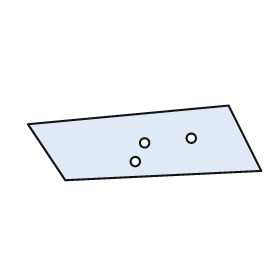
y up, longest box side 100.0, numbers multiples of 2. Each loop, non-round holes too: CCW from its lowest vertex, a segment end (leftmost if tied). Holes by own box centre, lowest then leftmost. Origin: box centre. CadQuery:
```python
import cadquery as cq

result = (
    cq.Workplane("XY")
    .moveTo(-34.0, -16.0)
    .lineTo(50.0, -12.0)
    .lineTo(36.0, 16.0)
    .lineTo(-50.0, 8.0)
    .close()
    .moveTo(-4.0, -8.0)
    .circle(2.0)
    .moveTo(0.0, 0.0)
    .circle(2.0)
    .moveTo(20.0, 2.0)
    .circle(2.0)
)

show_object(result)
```